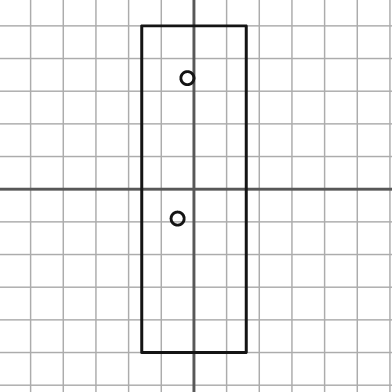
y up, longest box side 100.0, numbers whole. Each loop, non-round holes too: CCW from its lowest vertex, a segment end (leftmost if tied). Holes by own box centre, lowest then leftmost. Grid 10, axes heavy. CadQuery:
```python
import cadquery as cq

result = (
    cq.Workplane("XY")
    .moveTo(-16.0, -50.0)
    .lineTo(16.0, -50.0)
    .lineTo(16.0, 50.0)
    .lineTo(-16.0, 50.0)
    .close()
    .moveTo(-5.0, -9.0)
    .circle(2.0)
    .moveTo(-2.0, 34.0)
    .circle(2.0)
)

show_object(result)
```